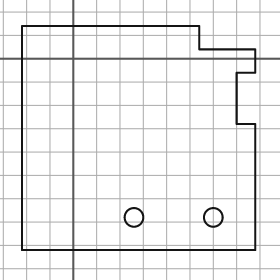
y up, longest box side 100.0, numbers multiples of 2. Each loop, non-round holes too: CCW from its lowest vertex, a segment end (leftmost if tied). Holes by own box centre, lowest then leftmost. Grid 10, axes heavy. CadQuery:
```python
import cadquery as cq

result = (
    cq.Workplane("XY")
    .moveTo(-22.0, -82.0)
    .lineTo(78.0, -82.0)
    .lineTo(78.0, -28.0)
    .lineTo(70.0, -28.0)
    .lineTo(70.0, -6.0)
    .lineTo(78.0, -6.0)
    .lineTo(78.0, 4.0)
    .lineTo(54.0, 4.0)
    .lineTo(54.0, 14.0)
    .lineTo(-22.0, 14.0)
    .close()
    .moveTo(26.0, -68.0)
    .circle(4.0)
    .moveTo(60.0, -68.0)
    .circle(4.0)
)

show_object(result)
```